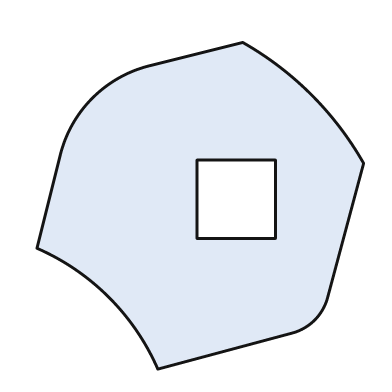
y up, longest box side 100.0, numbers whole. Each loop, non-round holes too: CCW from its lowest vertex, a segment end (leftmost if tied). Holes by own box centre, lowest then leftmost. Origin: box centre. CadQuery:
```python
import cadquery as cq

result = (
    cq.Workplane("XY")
    .moveTo(-13.0, -50.0)
    .lineTo(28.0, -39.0)
    .threePointArc((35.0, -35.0), (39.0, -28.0))
    .lineTo(50.0, 13.0)
    .threePointArc((34.0, 34.0), (13.0, 50.0))
    .lineTo(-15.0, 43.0)
    .threePointArc((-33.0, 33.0), (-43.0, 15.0))
    .lineTo(-50.0, -13.0)
    .threePointArc((-28.0, -28.0), (-13.0, -50.0))
    .close()
    .moveTo(-1.0, -10.0)
    .lineTo(23.0, -10.0)
    .lineTo(23.0, 14.0)
    .lineTo(-1.0, 14.0)
    .close()
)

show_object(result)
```